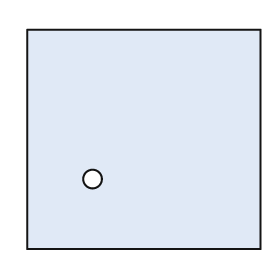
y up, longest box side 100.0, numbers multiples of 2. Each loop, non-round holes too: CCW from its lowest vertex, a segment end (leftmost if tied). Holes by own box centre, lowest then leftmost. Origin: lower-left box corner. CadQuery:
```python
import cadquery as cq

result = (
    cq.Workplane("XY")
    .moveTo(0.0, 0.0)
    .lineTo(100.0, 0.0)
    .lineTo(100.0, 94.0)
    .lineTo(0.0, 94.0)
    .close()
    .moveTo(28.0, 30.0)
    .circle(4.0)
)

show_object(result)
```